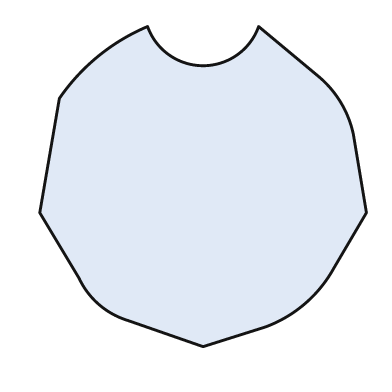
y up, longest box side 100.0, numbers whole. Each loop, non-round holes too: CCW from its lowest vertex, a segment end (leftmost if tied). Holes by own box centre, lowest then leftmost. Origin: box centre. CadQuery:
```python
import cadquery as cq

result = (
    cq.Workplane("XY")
    .moveTo(0.0, -49.0)
    .lineTo(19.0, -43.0)
    .threePointArc((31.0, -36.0), (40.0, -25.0))
    .lineTo(50.0, -8.0)
    .lineTo(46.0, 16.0)
    .threePointArc((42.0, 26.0), (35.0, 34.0))
    .lineTo(17.0, 49.0)
    .threePointArc((0.0, 37.0), (-17.0, 49.0))
    .threePointArc((-32.0, 40.0), (-44.0, 27.0))
    .lineTo(-50.0, -8.0)
    .lineTo(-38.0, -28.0)
    .threePointArc((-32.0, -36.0), (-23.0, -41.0))
    .close()
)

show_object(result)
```